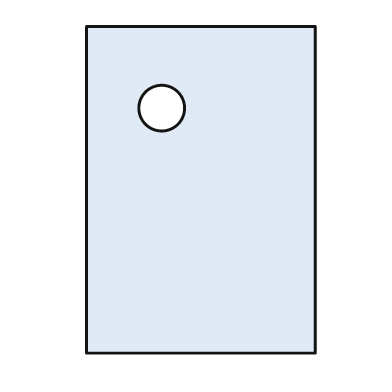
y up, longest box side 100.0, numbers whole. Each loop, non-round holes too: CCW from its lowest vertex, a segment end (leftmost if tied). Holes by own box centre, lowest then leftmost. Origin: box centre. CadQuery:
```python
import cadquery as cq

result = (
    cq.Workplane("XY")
    .moveTo(-35.0, -50.0)
    .lineTo(35.0, -50.0)
    .lineTo(35.0, 50.0)
    .lineTo(-35.0, 50.0)
    .close()
    .moveTo(-12.0, 25.0)
    .circle(7.0)
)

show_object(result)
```